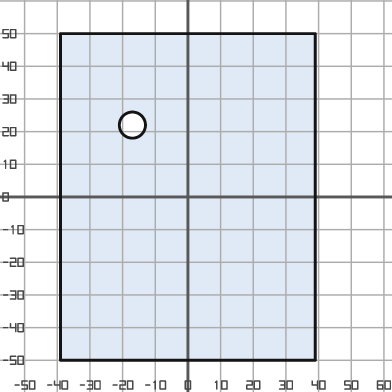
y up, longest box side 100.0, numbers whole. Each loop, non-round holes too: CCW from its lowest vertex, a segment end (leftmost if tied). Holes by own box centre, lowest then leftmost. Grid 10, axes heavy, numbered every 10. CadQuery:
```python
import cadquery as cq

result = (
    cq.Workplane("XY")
    .moveTo(-39.0, -50.0)
    .lineTo(39.0, -50.0)
    .lineTo(39.0, 50.0)
    .lineTo(-39.0, 50.0)
    .close()
    .moveTo(-17.0, 22.0)
    .circle(4.0)
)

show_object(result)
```